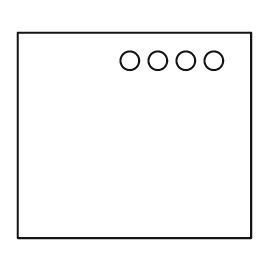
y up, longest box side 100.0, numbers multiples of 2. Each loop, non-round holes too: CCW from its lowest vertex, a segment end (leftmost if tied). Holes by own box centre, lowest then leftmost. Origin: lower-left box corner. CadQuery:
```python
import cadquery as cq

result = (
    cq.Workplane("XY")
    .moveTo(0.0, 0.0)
    .lineTo(100.0, 0.0)
    .lineTo(100.0, 88.0)
    .lineTo(0.0, 88.0)
    .close()
    .moveTo(48.0, 76.0)
    .circle(4.0)
    .moveTo(60.0, 76.0)
    .circle(4.0)
    .moveTo(72.0, 76.0)
    .circle(4.0)
    .moveTo(84.0, 76.0)
    .circle(4.0)
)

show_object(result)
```